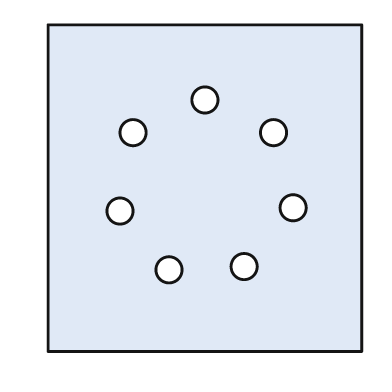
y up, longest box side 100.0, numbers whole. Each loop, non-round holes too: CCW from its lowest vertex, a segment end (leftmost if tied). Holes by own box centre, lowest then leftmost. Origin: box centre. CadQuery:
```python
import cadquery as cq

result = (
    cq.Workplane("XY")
    .moveTo(-48.0, -50.0)
    .lineTo(48.0, -50.0)
    .lineTo(48.0, 50.0)
    .lineTo(-48.0, 50.0)
    .close()
    .moveTo(-11.0, -25.0)
    .circle(4.0)
    .moveTo(12.0, -24.0)
    .circle(4.0)
    .moveTo(-26.0, -7.0)
    .circle(4.0)
    .moveTo(27.0, -6.0)
    .circle(4.0)
    .moveTo(-22.0, 17.0)
    .circle(4.0)
    .moveTo(21.0, 17.0)
    .circle(4.0)
    .moveTo(0.0, 27.0)
    .circle(4.0)
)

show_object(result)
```